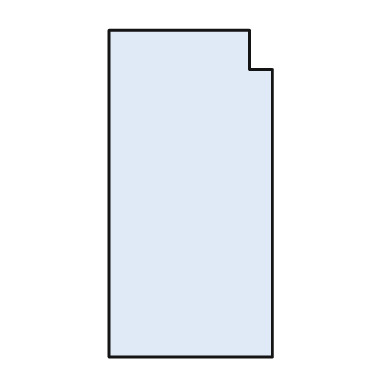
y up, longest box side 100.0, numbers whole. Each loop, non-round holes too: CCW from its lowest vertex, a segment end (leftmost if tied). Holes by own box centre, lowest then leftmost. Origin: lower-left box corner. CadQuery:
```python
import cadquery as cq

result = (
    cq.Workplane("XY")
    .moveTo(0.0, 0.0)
    .lineTo(50.0, 0.0)
    .lineTo(50.0, 88.0)
    .lineTo(43.0, 88.0)
    .lineTo(43.0, 100.0)
    .lineTo(0.0, 100.0)
    .close()
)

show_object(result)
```